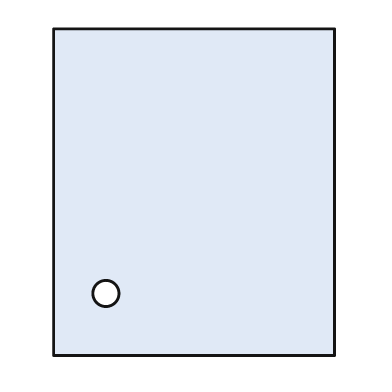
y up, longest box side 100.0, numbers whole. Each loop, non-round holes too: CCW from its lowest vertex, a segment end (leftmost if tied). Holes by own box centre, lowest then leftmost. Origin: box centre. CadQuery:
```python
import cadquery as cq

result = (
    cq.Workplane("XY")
    .moveTo(-43.0, -50.0)
    .lineTo(43.0, -50.0)
    .lineTo(43.0, 50.0)
    .lineTo(-43.0, 50.0)
    .close()
    .moveTo(-27.0, -31.0)
    .circle(4.0)
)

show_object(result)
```